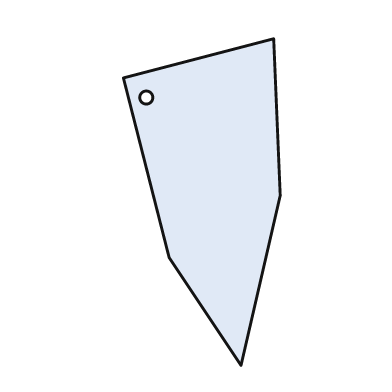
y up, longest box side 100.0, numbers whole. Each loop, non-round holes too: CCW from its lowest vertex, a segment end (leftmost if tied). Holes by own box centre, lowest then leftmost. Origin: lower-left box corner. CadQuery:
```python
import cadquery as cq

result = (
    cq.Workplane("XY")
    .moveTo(36.0, 0.0)
    .lineTo(48.0, 52.0)
    .lineTo(46.0, 100.0)
    .lineTo(0.0, 88.0)
    .lineTo(14.0, 33.0)
    .close()
    .moveTo(7.0, 82.0)
    .circle(2.0)
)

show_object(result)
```